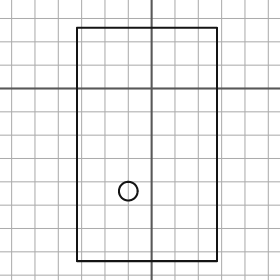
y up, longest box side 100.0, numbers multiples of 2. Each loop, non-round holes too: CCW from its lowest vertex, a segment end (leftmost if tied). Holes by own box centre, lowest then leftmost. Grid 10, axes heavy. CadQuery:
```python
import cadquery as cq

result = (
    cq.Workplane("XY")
    .moveTo(-32.0, -74.0)
    .lineTo(28.0, -74.0)
    .lineTo(28.0, 26.0)
    .lineTo(-32.0, 26.0)
    .close()
    .moveTo(-10.0, -44.0)
    .circle(4.0)
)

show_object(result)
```